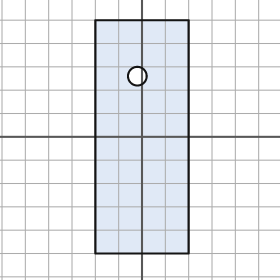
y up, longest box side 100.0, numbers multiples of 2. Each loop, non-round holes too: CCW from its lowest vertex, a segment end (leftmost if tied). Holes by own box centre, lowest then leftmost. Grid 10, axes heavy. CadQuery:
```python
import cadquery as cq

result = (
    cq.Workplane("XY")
    .moveTo(-20.0, -50.0)
    .lineTo(20.0, -50.0)
    .lineTo(20.0, 50.0)
    .lineTo(-20.0, 50.0)
    .close()
    .moveTo(-2.0, 26.0)
    .circle(4.0)
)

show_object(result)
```